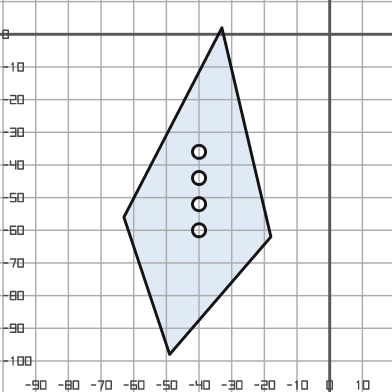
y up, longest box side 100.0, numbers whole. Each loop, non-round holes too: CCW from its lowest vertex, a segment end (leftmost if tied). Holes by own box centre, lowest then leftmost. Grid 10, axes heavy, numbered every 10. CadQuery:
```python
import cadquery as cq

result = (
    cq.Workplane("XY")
    .moveTo(-49.0, -98.0)
    .lineTo(-18.0, -62.0)
    .lineTo(-33.0, 2.0)
    .lineTo(-63.0, -56.0)
    .close()
    .moveTo(-40.0, -60.0)
    .circle(2.0)
    .moveTo(-40.0, -52.0)
    .circle(2.0)
    .moveTo(-40.0, -44.0)
    .circle(2.0)
    .moveTo(-40.0, -36.0)
    .circle(2.0)
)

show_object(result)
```